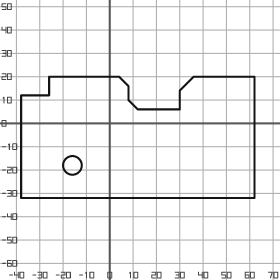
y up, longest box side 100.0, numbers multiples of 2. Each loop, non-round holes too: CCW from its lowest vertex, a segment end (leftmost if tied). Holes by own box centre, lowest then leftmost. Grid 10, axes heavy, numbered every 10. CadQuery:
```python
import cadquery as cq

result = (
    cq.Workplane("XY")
    .moveTo(-38.0, -32.0)
    .lineTo(62.0, -32.0)
    .lineTo(62.0, 20.0)
    .lineTo(36.0, 20.0)
    .lineTo(30.0, 14.0)
    .lineTo(30.0, 6.0)
    .lineTo(12.0, 6.0)
    .lineTo(8.0, 10.0)
    .lineTo(8.0, 16.0)
    .lineTo(4.0, 20.0)
    .lineTo(-26.0, 20.0)
    .lineTo(-26.0, 12.0)
    .lineTo(-38.0, 12.0)
    .close()
    .moveTo(-16.0, -18.0)
    .circle(4.0)
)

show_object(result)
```